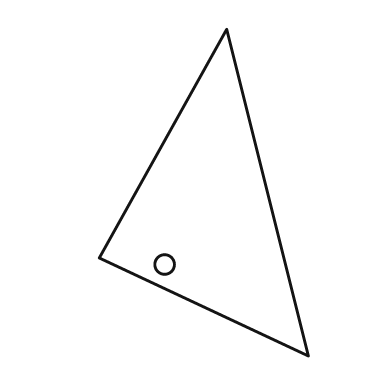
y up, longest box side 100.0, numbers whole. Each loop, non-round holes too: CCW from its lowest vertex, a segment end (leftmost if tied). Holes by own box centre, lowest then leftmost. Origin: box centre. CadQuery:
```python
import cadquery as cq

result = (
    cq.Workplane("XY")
    .moveTo(32.0, -50.0)
    .lineTo(7.0, 50.0)
    .lineTo(-32.0, -20.0)
    .close()
    .moveTo(-12.0, -22.0)
    .circle(3.0)
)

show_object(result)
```